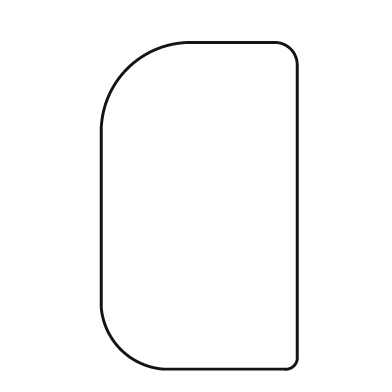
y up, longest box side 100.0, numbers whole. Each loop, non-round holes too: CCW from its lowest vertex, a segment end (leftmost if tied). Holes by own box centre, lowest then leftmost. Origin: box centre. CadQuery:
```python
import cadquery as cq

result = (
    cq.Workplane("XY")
    .moveTo(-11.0, -50.0)
    .lineTo(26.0, -50.0)
    .threePointArc((29.0, -49.0), (30.0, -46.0))
    .lineTo(30.0, 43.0)
    .threePointArc((28.0, 48.0), (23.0, 50.0))
    .lineTo(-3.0, 50.0)
    .threePointArc((-22.0, 42.0), (-30.0, 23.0))
    .lineTo(-30.0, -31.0)
    .threePointArc((-24.0, -44.0), (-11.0, -50.0))
    .close()
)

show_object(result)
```